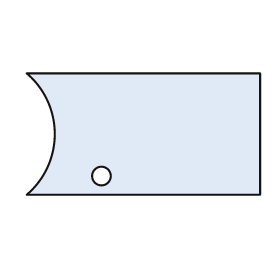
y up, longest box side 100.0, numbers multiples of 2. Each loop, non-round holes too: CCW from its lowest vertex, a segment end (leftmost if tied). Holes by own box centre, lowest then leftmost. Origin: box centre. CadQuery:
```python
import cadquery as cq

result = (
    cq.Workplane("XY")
    .moveTo(-50.0, -26.0)
    .lineTo(50.0, -26.0)
    .lineTo(50.0, 26.0)
    .lineTo(-50.0, 26.0)
    .threePointArc((-38.0, 0.0), (-50.0, -26.0))
    .close()
    .moveTo(-18.0, -18.0)
    .circle(4.0)
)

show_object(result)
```